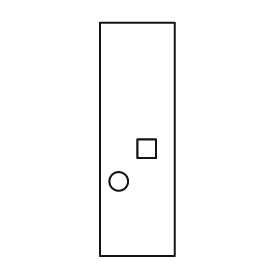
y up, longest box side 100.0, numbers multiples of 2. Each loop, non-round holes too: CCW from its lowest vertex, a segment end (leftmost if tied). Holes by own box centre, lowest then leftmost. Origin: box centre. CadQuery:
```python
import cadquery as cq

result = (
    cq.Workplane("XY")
    .moveTo(-16.0, -50.0)
    .lineTo(16.0, -50.0)
    .lineTo(16.0, 50.0)
    .lineTo(-16.0, 50.0)
    .close()
    .moveTo(-8.0, -18.0)
    .circle(4.0)
    .moveTo(0.0, -8.0)
    .lineTo(8.0, -8.0)
    .lineTo(8.0, 0.0)
    .lineTo(0.0, 0.0)
    .close()
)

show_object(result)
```